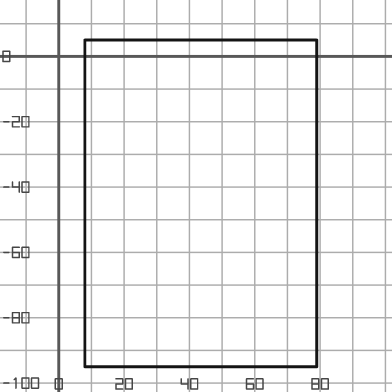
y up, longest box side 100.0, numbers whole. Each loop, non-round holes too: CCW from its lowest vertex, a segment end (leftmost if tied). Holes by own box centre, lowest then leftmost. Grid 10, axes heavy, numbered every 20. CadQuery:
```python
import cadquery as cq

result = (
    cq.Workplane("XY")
    .moveTo(8.0, -95.0)
    .lineTo(79.0, -95.0)
    .lineTo(79.0, 5.0)
    .lineTo(8.0, 5.0)
    .close()
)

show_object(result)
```